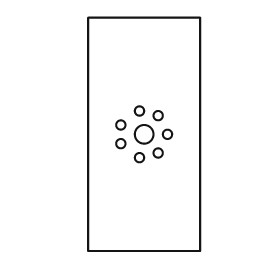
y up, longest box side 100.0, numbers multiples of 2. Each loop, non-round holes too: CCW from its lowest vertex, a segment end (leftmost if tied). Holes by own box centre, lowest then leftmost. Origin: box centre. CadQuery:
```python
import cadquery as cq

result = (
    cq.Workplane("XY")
    .moveTo(-24.0, -50.0)
    .lineTo(24.0, -50.0)
    .lineTo(24.0, 50.0)
    .lineTo(-24.0, 50.0)
    .close()
    .moveTo(-2.0, -10.0)
    .circle(2.0)
    .moveTo(6.0, -8.0)
    .circle(2.0)
    .moveTo(-10.0, -4.0)
    .circle(2.0)
    .moveTo(0.0, 0.0)
    .circle(4.0)
    .moveTo(10.0, 0.0)
    .circle(2.0)
    .moveTo(-10.0, 4.0)
    .circle(2.0)
    .moveTo(6.0, 8.0)
    .circle(2.0)
    .moveTo(-2.0, 10.0)
    .circle(2.0)
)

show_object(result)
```